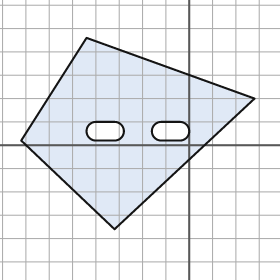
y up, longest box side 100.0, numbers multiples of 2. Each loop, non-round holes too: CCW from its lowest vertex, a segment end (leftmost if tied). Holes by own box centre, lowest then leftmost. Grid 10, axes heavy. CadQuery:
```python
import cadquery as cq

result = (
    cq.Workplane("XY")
    .moveTo(-32.0, -36.0)
    .lineTo(28.0, 20.0)
    .lineTo(-44.0, 46.0)
    .lineTo(-72.0, 2.0)
    .close()
    .moveTo(-40.0, 2.0)
    .lineTo(-32.0, 2.0)
    .threePointArc((-28.0, 6.0), (-32.0, 10.0))
    .lineTo(-40.0, 10.0)
    .threePointArc((-44.0, 6.0), (-40.0, 2.0))
    .close()
    .moveTo(-12.0, 2.0)
    .lineTo(-4.0, 2.0)
    .threePointArc((0.0, 6.0), (-4.0, 10.0))
    .lineTo(-12.0, 10.0)
    .threePointArc((-16.0, 6.0), (-12.0, 2.0))
    .close()
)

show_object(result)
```